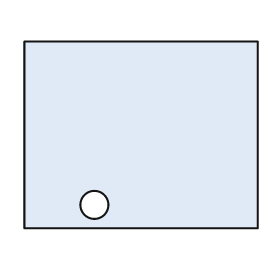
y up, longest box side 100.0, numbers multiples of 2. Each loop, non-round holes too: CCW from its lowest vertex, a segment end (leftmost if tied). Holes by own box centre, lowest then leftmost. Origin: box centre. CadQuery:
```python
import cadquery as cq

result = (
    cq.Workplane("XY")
    .moveTo(-50.0, -40.0)
    .lineTo(50.0, -40.0)
    .lineTo(50.0, 40.0)
    .lineTo(-50.0, 40.0)
    .close()
    .moveTo(-20.0, -30.0)
    .circle(6.0)
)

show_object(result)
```